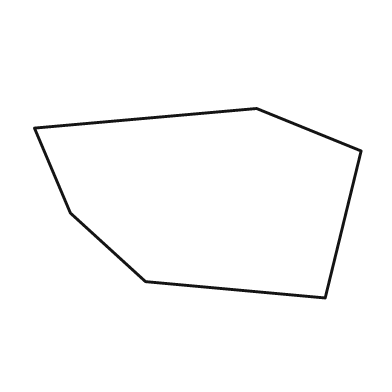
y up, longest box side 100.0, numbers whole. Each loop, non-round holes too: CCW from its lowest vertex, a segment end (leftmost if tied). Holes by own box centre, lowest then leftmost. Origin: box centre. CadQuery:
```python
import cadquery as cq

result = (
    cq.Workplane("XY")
    .moveTo(39.0, -29.0)
    .lineTo(50.0, 16.0)
    .lineTo(18.0, 29.0)
    .lineTo(-50.0, 23.0)
    .lineTo(-39.0, -3.0)
    .lineTo(-16.0, -24.0)
    .close()
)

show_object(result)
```